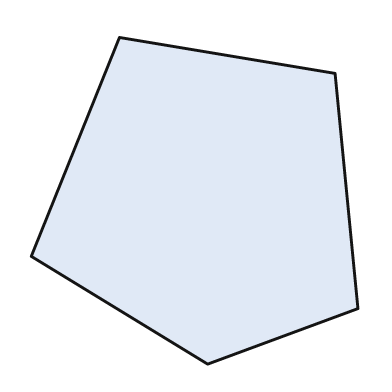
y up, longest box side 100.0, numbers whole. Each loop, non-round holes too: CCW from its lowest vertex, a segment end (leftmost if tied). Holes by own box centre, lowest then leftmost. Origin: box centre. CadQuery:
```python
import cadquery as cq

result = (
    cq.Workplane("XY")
    .moveTo(4.0, -50.0)
    .lineTo(50.0, -33.0)
    .lineTo(43.0, 39.0)
    .lineTo(-23.0, 50.0)
    .lineTo(-50.0, -17.0)
    .close()
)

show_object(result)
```